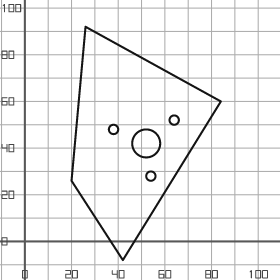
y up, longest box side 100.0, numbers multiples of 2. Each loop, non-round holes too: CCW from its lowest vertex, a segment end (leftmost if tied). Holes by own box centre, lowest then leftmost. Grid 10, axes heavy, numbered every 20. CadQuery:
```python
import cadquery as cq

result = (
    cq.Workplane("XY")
    .moveTo(42.0, -8.0)
    .lineTo(84.0, 60.0)
    .lineTo(26.0, 92.0)
    .lineTo(20.0, 26.0)
    .close()
    .moveTo(54.0, 28.0)
    .circle(2.0)
    .moveTo(52.0, 42.0)
    .circle(6.0)
    .moveTo(38.0, 48.0)
    .circle(2.0)
    .moveTo(64.0, 52.0)
    .circle(2.0)
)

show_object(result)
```